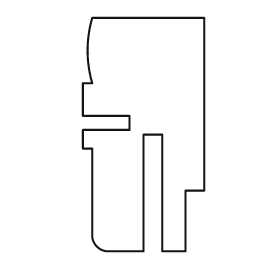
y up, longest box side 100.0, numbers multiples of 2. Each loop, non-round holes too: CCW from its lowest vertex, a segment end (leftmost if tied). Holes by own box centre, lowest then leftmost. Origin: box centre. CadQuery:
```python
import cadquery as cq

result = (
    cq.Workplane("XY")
    .moveTo(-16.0, -50.0)
    .lineTo(0.0, -50.0)
    .lineTo(0.0, 0.0)
    .lineTo(8.0, 0.0)
    .lineTo(8.0, -50.0)
    .lineTo(18.0, -50.0)
    .lineTo(18.0, -24.0)
    .lineTo(26.0, -24.0)
    .lineTo(26.0, 50.0)
    .lineTo(-22.0, 50.0)
    .threePointArc((-24.0, 36.0), (-22.0, 22.0))
    .lineTo(-26.0, 22.0)
    .lineTo(-26.0, 8.0)
    .lineTo(-6.0, 8.0)
    .lineTo(-6.0, 2.0)
    .lineTo(-26.0, 2.0)
    .lineTo(-26.0, -6.0)
    .lineTo(-22.0, -6.0)
    .lineTo(-22.0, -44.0)
    .threePointArc((-20.0, -48.0), (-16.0, -50.0))
    .close()
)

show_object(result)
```